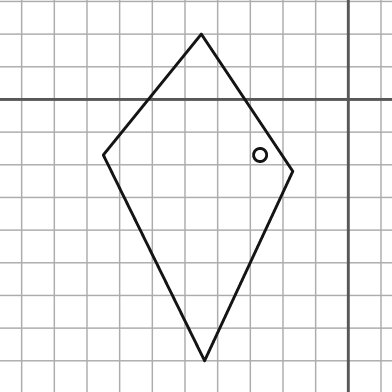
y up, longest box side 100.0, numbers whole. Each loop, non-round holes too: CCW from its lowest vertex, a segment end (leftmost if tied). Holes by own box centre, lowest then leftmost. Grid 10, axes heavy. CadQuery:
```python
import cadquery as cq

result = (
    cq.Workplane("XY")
    .moveTo(-44.0, -80.0)
    .lineTo(-17.0, -22.0)
    .lineTo(-45.0, 20.0)
    .lineTo(-75.0, -17.0)
    .close()
    .moveTo(-27.0, -17.0)
    .circle(2.0)
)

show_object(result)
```